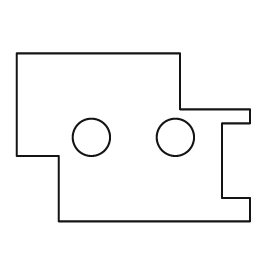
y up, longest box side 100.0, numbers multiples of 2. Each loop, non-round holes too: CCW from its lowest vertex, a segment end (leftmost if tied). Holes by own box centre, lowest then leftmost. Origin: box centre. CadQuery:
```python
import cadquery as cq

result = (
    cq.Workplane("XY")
    .moveTo(-32.0, -36.0)
    .lineTo(50.0, -36.0)
    .lineTo(50.0, -26.0)
    .lineTo(38.0, -26.0)
    .lineTo(38.0, 6.0)
    .lineTo(50.0, 6.0)
    .lineTo(50.0, 12.0)
    .lineTo(20.0, 12.0)
    .lineTo(20.0, 36.0)
    .lineTo(-50.0, 36.0)
    .lineTo(-50.0, -8.0)
    .lineTo(-32.0, -8.0)
    .close()
    .moveTo(-18.0, 0.0)
    .circle(8.0)
    .moveTo(18.0, 0.0)
    .circle(8.0)
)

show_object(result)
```